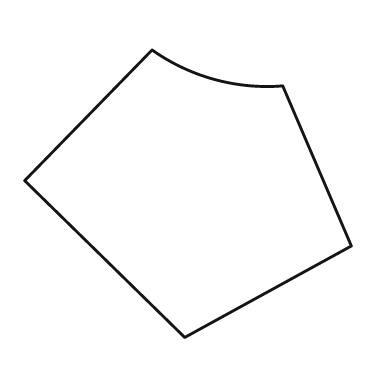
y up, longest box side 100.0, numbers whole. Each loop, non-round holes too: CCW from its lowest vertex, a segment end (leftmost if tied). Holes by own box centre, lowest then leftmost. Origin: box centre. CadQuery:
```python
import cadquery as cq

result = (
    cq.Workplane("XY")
    .moveTo(-1.0, -44.0)
    .lineTo(50.0, -16.0)
    .lineTo(29.0, 33.0)
    .threePointArc((8.0, 35.0), (-11.0, 44.0))
    .lineTo(-50.0, 4.0)
    .close()
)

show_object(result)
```